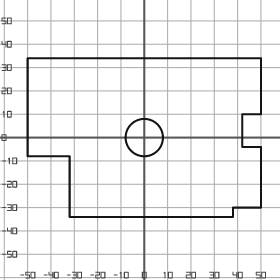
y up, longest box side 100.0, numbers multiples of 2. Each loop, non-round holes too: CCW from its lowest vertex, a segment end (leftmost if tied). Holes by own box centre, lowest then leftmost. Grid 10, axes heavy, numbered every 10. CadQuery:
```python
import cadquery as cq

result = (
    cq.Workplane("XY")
    .moveTo(-32.0, -34.0)
    .lineTo(38.0, -34.0)
    .lineTo(38.0, -30.0)
    .lineTo(50.0, -30.0)
    .lineTo(50.0, -4.0)
    .lineTo(42.0, -4.0)
    .lineTo(42.0, 10.0)
    .lineTo(50.0, 10.0)
    .lineTo(50.0, 34.0)
    .lineTo(-50.0, 34.0)
    .lineTo(-50.0, -8.0)
    .lineTo(-32.0, -8.0)
    .close()
    .moveTo(0.0, 0.0)
    .circle(8.0)
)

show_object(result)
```